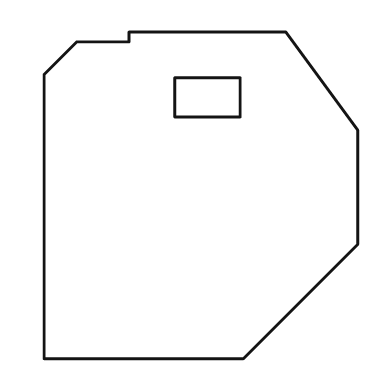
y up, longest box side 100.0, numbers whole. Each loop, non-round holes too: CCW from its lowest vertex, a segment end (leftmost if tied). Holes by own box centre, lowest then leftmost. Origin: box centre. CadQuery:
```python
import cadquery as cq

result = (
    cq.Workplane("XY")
    .moveTo(-48.0, -50.0)
    .lineTo(13.0, -50.0)
    .lineTo(48.0, -15.0)
    .lineTo(48.0, 20.0)
    .lineTo(26.0, 50.0)
    .lineTo(-22.0, 50.0)
    .lineTo(-22.0, 47.0)
    .lineTo(-38.0, 47.0)
    .lineTo(-48.0, 37.0)
    .close()
    .moveTo(-8.0, 24.0)
    .lineTo(12.0, 24.0)
    .lineTo(12.0, 36.0)
    .lineTo(-8.0, 36.0)
    .close()
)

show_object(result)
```